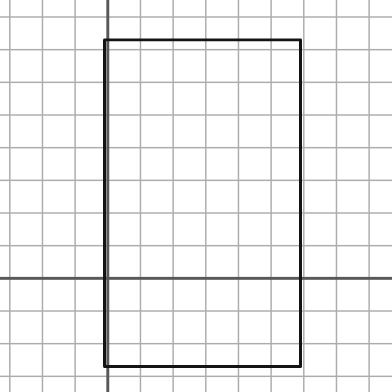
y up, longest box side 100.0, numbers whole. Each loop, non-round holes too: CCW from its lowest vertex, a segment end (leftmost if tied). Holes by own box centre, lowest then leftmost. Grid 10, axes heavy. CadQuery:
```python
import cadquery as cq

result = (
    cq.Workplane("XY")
    .moveTo(-1.0, -27.0)
    .lineTo(59.0, -27.0)
    .lineTo(59.0, 73.0)
    .lineTo(-1.0, 73.0)
    .close()
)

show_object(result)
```